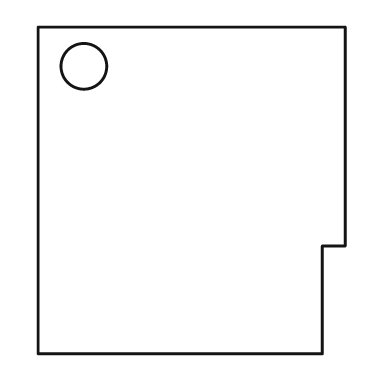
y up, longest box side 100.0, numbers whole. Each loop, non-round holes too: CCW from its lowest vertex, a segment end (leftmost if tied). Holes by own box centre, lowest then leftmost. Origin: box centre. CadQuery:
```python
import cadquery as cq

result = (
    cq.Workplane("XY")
    .moveTo(-47.0, -50.0)
    .lineTo(40.0, -50.0)
    .lineTo(40.0, -17.0)
    .lineTo(47.0, -17.0)
    .lineTo(47.0, 50.0)
    .lineTo(-47.0, 50.0)
    .close()
    .moveTo(-33.0, 38.0)
    .circle(7.0)
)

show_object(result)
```